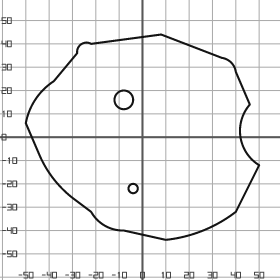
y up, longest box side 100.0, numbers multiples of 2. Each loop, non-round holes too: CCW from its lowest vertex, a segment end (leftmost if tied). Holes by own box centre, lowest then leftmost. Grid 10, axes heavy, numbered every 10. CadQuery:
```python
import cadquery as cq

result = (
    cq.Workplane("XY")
    .moveTo(10.0, -44.0)
    .threePointArc((26.0, -40.0), (40.0, -32.0))
    .lineTo(50.0, -12.0)
    .threePointArc((42.0, 0.0), (46.0, 14.0))
    .lineTo(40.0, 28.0)
    .threePointArc((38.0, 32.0), (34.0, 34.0))
    .lineTo(8.0, 44.0)
    .lineTo(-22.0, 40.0)
    .threePointArc((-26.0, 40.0), (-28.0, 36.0))
    .lineTo(-38.0, 24.0)
    .threePointArc((-46.0, 16.0), (-50.0, 6.0))
    .lineTo(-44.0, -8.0)
    .threePointArc((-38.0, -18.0), (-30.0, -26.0))
    .lineTo(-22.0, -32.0)
    .threePointArc((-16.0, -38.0), (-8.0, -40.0))
    .close()
    .moveTo(-4.0, -22.0)
    .circle(2.0)
    .moveTo(-8.0, 16.0)
    .circle(4.0)
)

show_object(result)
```